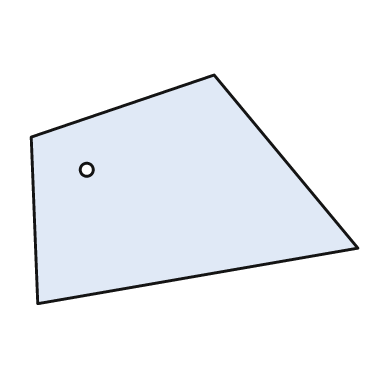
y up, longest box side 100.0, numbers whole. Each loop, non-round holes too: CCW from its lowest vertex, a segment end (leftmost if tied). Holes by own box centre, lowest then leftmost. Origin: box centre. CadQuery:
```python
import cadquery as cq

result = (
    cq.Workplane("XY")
    .moveTo(-48.0, -35.0)
    .lineTo(50.0, -18.0)
    .lineTo(6.0, 35.0)
    .lineTo(-50.0, 16.0)
    .close()
    .moveTo(-33.0, 6.0)
    .circle(2.0)
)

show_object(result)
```